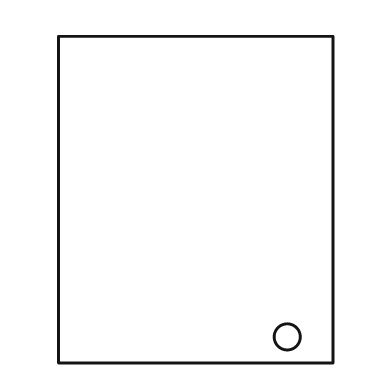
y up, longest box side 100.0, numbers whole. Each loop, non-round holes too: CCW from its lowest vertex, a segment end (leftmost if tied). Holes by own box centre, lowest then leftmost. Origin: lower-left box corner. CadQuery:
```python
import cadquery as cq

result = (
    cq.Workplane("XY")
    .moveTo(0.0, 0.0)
    .lineTo(84.0, 0.0)
    .lineTo(84.0, 100.0)
    .lineTo(0.0, 100.0)
    .close()
    .moveTo(70.0, 8.0)
    .circle(4.0)
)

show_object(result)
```